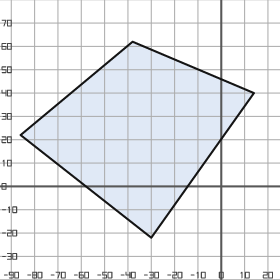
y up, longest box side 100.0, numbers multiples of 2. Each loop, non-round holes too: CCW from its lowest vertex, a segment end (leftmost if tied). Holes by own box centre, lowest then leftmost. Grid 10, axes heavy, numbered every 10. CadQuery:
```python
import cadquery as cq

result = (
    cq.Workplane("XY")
    .moveTo(-30.0, -22.0)
    .lineTo(14.0, 40.0)
    .lineTo(-38.0, 62.0)
    .lineTo(-86.0, 22.0)
    .close()
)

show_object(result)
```